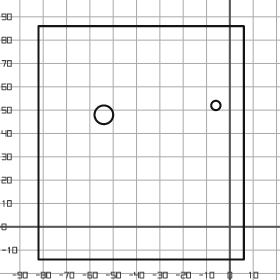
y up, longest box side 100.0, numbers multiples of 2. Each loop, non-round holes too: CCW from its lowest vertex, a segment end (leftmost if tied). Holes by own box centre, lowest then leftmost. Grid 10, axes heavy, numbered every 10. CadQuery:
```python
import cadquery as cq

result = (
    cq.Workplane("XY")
    .moveTo(-82.0, -14.0)
    .lineTo(6.0, -14.0)
    .lineTo(6.0, 86.0)
    .lineTo(-82.0, 86.0)
    .close()
    .moveTo(-54.0, 48.0)
    .circle(4.0)
    .moveTo(-6.0, 52.0)
    .circle(2.0)
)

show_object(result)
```